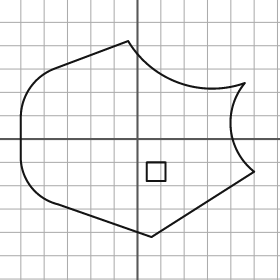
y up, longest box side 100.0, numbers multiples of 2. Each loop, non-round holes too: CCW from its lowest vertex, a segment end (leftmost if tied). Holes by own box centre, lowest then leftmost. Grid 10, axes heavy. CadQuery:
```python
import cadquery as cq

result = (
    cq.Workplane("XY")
    .moveTo(6.0, -42.0)
    .lineTo(50.0, -14.0)
    .threePointArc((40.0, 4.0), (46.0, 24.0))
    .threePointArc((18.0, 24.0), (-4.0, 42.0))
    .lineTo(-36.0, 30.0)
    .threePointArc((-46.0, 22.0), (-50.0, 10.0))
    .lineTo(-50.0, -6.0)
    .threePointArc((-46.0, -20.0), (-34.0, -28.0))
    .close()
    .moveTo(4.0, -18.0)
    .lineTo(12.0, -18.0)
    .lineTo(12.0, -10.0)
    .lineTo(4.0, -10.0)
    .close()
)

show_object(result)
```